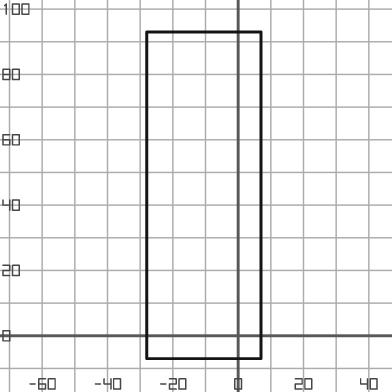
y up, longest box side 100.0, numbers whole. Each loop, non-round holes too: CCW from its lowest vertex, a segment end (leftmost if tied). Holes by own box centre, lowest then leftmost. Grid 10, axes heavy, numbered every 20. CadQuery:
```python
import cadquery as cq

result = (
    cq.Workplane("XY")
    .moveTo(-28.0, -7.0)
    .lineTo(7.0, -7.0)
    .lineTo(7.0, 93.0)
    .lineTo(-28.0, 93.0)
    .close()
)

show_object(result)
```